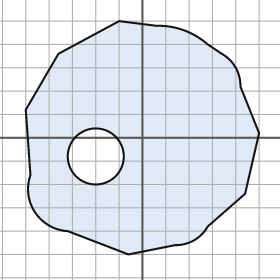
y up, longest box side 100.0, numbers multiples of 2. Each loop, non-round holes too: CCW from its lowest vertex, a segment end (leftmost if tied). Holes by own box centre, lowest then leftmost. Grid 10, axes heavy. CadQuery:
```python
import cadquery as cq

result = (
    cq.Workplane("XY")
    .moveTo(-6.0, -50.0)
    .lineTo(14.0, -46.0)
    .threePointArc((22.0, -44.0), (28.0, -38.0))
    .lineTo(44.0, -24.0)
    .lineTo(50.0, 2.0)
    .lineTo(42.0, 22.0)
    .threePointArc((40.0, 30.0), (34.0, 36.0))
    .lineTo(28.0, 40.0)
    .threePointArc((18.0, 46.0), (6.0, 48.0))
    .lineTo(-10.0, 50.0)
    .lineTo(-36.0, 36.0)
    .lineTo(-50.0, 12.0)
    .lineTo(-48.0, -16.0)
    .threePointArc((-46.0, -32.0), (-32.0, -40.0))
    .close()
    .moveTo(-20.0, -8.0)
    .circle(12.0)
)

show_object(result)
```